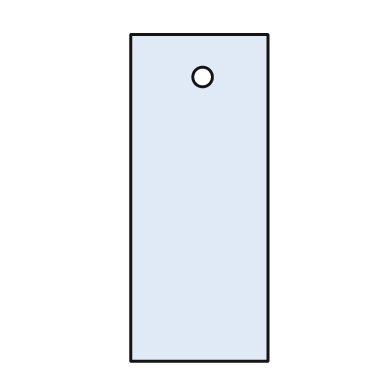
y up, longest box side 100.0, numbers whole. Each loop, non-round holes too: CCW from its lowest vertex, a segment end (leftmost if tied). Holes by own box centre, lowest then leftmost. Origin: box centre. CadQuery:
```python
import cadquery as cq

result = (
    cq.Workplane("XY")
    .moveTo(-21.0, -50.0)
    .lineTo(21.0, -50.0)
    .lineTo(21.0, 50.0)
    .lineTo(-21.0, 50.0)
    .close()
    .moveTo(1.0, 37.0)
    .circle(3.0)
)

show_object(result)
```